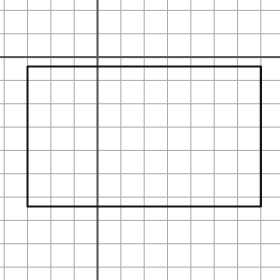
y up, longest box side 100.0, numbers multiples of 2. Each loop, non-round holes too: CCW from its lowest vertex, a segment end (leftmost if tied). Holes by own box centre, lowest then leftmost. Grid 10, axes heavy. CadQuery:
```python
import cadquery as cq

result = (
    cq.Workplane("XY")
    .moveTo(-30.0, -64.0)
    .lineTo(70.0, -64.0)
    .lineTo(70.0, -4.0)
    .lineTo(-30.0, -4.0)
    .close()
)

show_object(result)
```